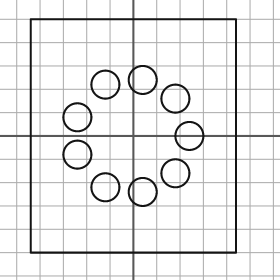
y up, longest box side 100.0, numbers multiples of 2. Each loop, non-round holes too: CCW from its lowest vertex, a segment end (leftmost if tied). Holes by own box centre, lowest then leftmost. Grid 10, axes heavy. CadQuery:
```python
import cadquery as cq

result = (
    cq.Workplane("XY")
    .moveTo(-44.0, -50.0)
    .lineTo(44.0, -50.0)
    .lineTo(44.0, 50.0)
    .lineTo(-44.0, 50.0)
    .close()
    .moveTo(4.0, -24.0)
    .circle(6.0)
    .moveTo(-12.0, -22.0)
    .circle(6.0)
    .moveTo(18.0, -16.0)
    .circle(6.0)
    .moveTo(-24.0, -8.0)
    .circle(6.0)
    .moveTo(24.0, 0.0)
    .circle(6.0)
    .moveTo(-24.0, 8.0)
    .circle(6.0)
    .moveTo(18.0, 16.0)
    .circle(6.0)
    .moveTo(-12.0, 22.0)
    .circle(6.0)
    .moveTo(4.0, 24.0)
    .circle(6.0)
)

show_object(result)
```